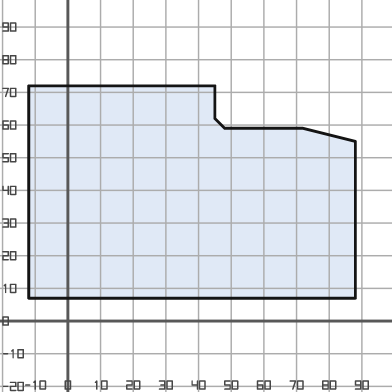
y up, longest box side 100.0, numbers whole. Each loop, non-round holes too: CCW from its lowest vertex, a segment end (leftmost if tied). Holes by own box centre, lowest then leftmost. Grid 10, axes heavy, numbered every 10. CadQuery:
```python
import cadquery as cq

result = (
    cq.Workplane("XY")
    .moveTo(-12.0, 7.0)
    .lineTo(88.0, 7.0)
    .lineTo(88.0, 55.0)
    .lineTo(72.0, 59.0)
    .lineTo(48.0, 59.0)
    .lineTo(45.0, 62.0)
    .lineTo(45.0, 72.0)
    .lineTo(-12.0, 72.0)
    .close()
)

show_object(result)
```